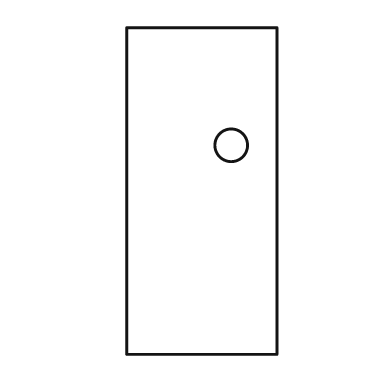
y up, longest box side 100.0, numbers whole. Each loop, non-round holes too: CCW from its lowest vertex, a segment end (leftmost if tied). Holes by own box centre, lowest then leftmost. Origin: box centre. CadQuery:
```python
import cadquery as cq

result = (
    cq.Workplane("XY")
    .moveTo(-23.0, -50.0)
    .lineTo(23.0, -50.0)
    .lineTo(23.0, 50.0)
    .lineTo(-23.0, 50.0)
    .close()
    .moveTo(9.0, 14.0)
    .circle(5.0)
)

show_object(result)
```